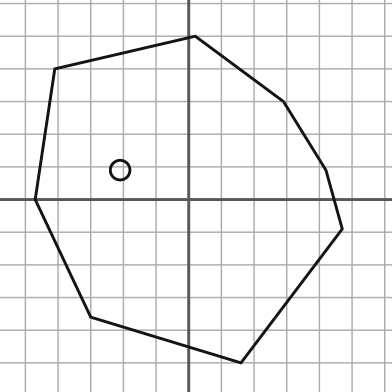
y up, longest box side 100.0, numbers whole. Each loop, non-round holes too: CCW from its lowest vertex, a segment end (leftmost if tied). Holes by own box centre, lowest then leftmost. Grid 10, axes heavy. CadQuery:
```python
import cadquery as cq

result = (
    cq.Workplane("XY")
    .moveTo(16.0, -50.0)
    .lineTo(47.0, -9.0)
    .lineTo(42.0, 9.0)
    .lineTo(29.0, 30.0)
    .lineTo(2.0, 50.0)
    .lineTo(-41.0, 40.0)
    .lineTo(-47.0, 0.0)
    .lineTo(-30.0, -36.0)
    .close()
    .moveTo(-21.0, 9.0)
    .circle(3.0)
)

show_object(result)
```